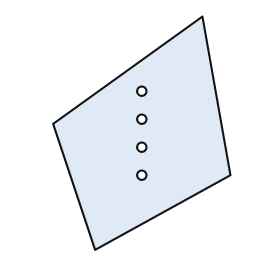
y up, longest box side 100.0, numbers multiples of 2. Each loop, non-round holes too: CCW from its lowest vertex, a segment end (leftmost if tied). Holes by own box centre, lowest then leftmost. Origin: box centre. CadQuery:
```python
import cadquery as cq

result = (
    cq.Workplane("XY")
    .moveTo(-20.0, -50.0)
    .lineTo(38.0, -18.0)
    .lineTo(26.0, 50.0)
    .lineTo(-38.0, 4.0)
    .close()
    .moveTo(0.0, -18.0)
    .circle(2.0)
    .moveTo(0.0, -6.0)
    .circle(2.0)
    .moveTo(0.0, 6.0)
    .circle(2.0)
    .moveTo(0.0, 18.0)
    .circle(2.0)
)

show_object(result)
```